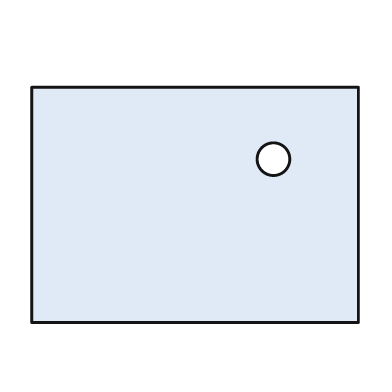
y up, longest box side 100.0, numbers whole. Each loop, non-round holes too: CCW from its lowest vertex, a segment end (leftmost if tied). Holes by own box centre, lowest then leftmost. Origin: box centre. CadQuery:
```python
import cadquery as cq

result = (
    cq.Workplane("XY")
    .moveTo(-50.0, -36.0)
    .lineTo(50.0, -36.0)
    .lineTo(50.0, 36.0)
    .lineTo(-50.0, 36.0)
    .close()
    .moveTo(24.0, 14.0)
    .circle(5.0)
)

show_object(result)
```